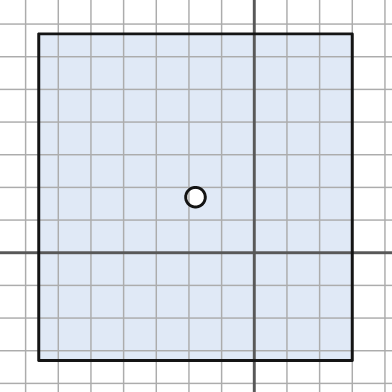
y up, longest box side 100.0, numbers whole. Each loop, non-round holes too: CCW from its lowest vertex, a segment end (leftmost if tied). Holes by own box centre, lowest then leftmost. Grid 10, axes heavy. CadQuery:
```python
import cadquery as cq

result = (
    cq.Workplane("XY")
    .moveTo(-66.0, -33.0)
    .lineTo(30.0, -33.0)
    .lineTo(30.0, 67.0)
    .lineTo(-66.0, 67.0)
    .close()
    .moveTo(-18.0, 17.0)
    .circle(3.0)
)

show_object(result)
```